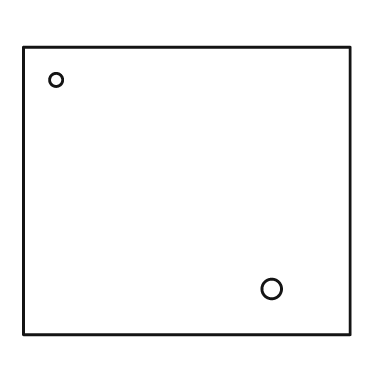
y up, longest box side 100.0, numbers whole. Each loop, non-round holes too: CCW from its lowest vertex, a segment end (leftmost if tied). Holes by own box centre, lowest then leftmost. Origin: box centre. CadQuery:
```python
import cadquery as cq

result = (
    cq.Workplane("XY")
    .moveTo(-50.0, -44.0)
    .lineTo(50.0, -44.0)
    .lineTo(50.0, 44.0)
    .lineTo(-50.0, 44.0)
    .close()
    .moveTo(26.0, -30.0)
    .circle(3.0)
    .moveTo(-40.0, 34.0)
    .circle(2.0)
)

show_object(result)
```